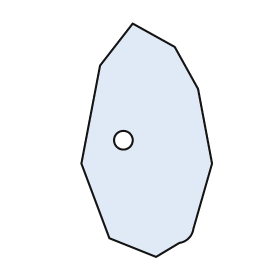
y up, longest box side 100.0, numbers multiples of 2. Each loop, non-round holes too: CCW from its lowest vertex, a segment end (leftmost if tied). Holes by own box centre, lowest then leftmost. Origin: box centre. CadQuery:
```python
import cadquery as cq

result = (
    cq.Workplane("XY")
    .moveTo(4.0, -50.0)
    .lineTo(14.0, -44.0)
    .threePointArc((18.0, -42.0), (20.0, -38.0))
    .lineTo(28.0, -10.0)
    .lineTo(22.0, 22.0)
    .lineTo(12.0, 40.0)
    .lineTo(-6.0, 50.0)
    .lineTo(-20.0, 32.0)
    .lineTo(-28.0, -10.0)
    .lineTo(-16.0, -42.0)
    .close()
    .moveTo(-10.0, 0.0)
    .circle(4.0)
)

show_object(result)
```